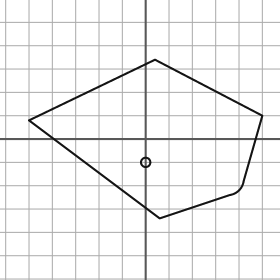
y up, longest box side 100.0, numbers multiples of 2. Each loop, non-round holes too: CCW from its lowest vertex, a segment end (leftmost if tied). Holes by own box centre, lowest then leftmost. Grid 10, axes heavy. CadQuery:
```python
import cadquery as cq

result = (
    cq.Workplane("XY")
    .moveTo(6.0, -34.0)
    .lineTo(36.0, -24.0)
    .threePointArc((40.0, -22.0), (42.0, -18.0))
    .lineTo(50.0, 10.0)
    .lineTo(4.0, 34.0)
    .lineTo(-50.0, 8.0)
    .close()
    .moveTo(0.0, -10.0)
    .circle(2.0)
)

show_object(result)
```